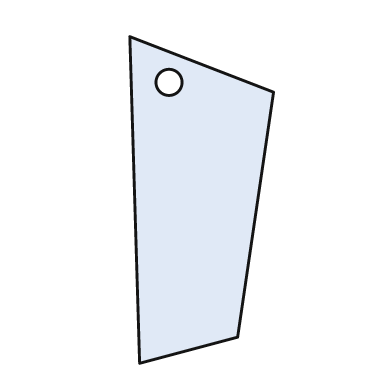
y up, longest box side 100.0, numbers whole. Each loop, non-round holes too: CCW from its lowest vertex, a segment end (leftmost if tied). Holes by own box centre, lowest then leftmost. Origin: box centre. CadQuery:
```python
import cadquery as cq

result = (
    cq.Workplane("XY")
    .moveTo(-19.0, -50.0)
    .lineTo(11.0, -42.0)
    .lineTo(22.0, 33.0)
    .lineTo(-22.0, 50.0)
    .close()
    .moveTo(-10.0, 36.0)
    .circle(4.0)
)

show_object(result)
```